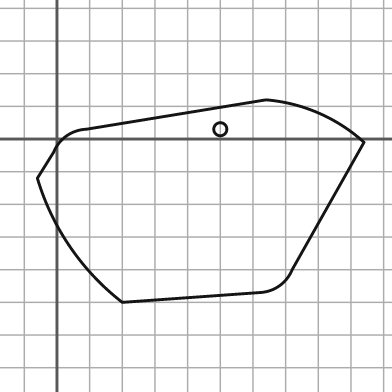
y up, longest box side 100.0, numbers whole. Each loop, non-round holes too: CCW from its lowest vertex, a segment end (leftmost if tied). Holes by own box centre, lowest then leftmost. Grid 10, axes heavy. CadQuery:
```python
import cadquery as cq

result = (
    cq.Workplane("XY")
    .moveTo(20.0, -50.0)
    .lineTo(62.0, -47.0)
    .threePointArc((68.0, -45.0), (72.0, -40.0))
    .lineTo(94.0, -1.0)
    .threePointArc((80.0, 8.0), (64.0, 12.0))
    .lineTo(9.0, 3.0)
    .threePointArc((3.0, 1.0), (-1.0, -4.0))
    .lineTo(-6.0, -12.0)
    .threePointArc((4.0, -33.0), (20.0, -50.0))
    .close()
    .moveTo(50.0, 3.0)
    .circle(2.0)
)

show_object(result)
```